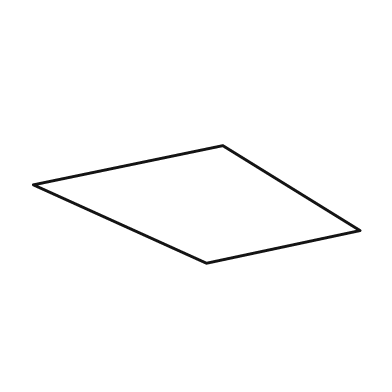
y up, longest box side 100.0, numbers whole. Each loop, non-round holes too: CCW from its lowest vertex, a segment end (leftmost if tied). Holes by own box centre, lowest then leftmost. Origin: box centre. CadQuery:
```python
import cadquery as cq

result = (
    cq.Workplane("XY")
    .moveTo(3.0, -18.0)
    .lineTo(50.0, -8.0)
    .lineTo(8.0, 18.0)
    .lineTo(-50.0, 6.0)
    .close()
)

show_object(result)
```